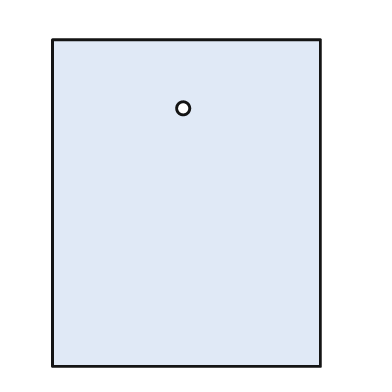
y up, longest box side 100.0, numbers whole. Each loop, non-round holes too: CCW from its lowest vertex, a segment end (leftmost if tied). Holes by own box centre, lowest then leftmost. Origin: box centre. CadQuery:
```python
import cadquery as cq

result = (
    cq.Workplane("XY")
    .moveTo(-41.0, -50.0)
    .lineTo(41.0, -50.0)
    .lineTo(41.0, 50.0)
    .lineTo(-41.0, 50.0)
    .close()
    .moveTo(-1.0, 29.0)
    .circle(2.0)
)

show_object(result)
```